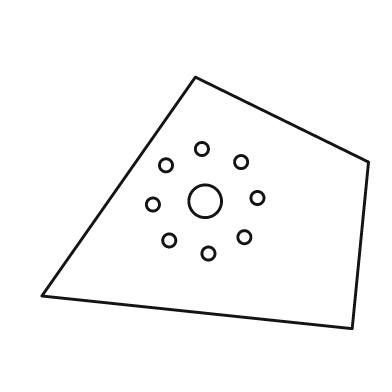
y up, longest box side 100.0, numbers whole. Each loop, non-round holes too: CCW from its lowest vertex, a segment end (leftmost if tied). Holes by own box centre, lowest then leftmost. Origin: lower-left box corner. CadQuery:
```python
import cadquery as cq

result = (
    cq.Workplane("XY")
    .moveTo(95.0, 0.0)
    .lineTo(100.0, 51.0)
    .lineTo(47.0, 77.0)
    .lineTo(0.0, 10.0)
    .close()
    .moveTo(51.0, 23.0)
    .circle(2.0)
    .moveTo(39.0, 27.0)
    .circle(2.0)
    .moveTo(62.0, 28.0)
    .circle(2.0)
    .moveTo(34.0, 38.0)
    .circle(2.0)
    .moveTo(50.0, 39.0)
    .circle(5.0)
    .moveTo(66.0, 40.0)
    .circle(2.0)
    .moveTo(38.0, 50.0)
    .circle(2.0)
    .moveTo(61.0, 51.0)
    .circle(2.0)
    .moveTo(49.0, 55.0)
    .circle(2.0)
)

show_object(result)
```